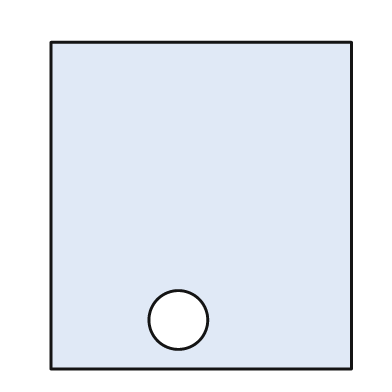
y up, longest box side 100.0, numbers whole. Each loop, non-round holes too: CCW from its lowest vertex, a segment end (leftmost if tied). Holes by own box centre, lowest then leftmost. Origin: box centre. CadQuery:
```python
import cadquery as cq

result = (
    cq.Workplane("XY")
    .moveTo(-46.0, -50.0)
    .lineTo(46.0, -50.0)
    .lineTo(46.0, 50.0)
    .lineTo(-46.0, 50.0)
    .close()
    .moveTo(-7.0, -35.0)
    .circle(9.0)
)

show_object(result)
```